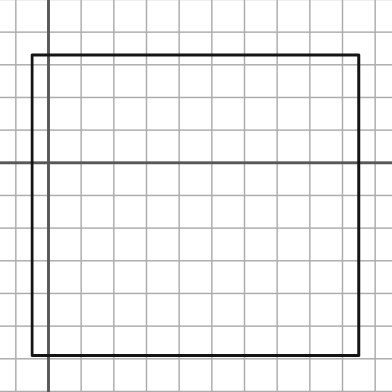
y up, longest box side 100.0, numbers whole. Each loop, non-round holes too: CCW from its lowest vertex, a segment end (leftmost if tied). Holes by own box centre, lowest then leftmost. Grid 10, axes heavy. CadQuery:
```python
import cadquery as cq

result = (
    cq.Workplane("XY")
    .moveTo(-5.0, -59.0)
    .lineTo(95.0, -59.0)
    .lineTo(95.0, 33.0)
    .lineTo(-5.0, 33.0)
    .close()
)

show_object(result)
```